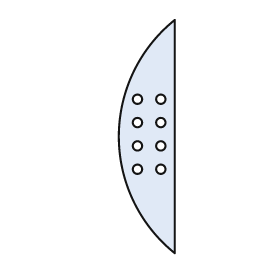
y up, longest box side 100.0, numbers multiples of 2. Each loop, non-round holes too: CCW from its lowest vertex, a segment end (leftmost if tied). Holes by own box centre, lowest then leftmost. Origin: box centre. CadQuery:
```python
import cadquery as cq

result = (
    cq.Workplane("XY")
    .moveTo(12.0, -50.0)
    .lineTo(12.0, 50.0)
    .threePointArc((-12.0, 0.0), (12.0, -50.0))
    .close()
    .moveTo(-4.0, -14.0)
    .circle(2.0)
    .moveTo(6.0, -14.0)
    .circle(2.0)
    .moveTo(-4.0, -4.0)
    .circle(2.0)
    .moveTo(6.0, -4.0)
    .circle(2.0)
    .moveTo(-4.0, 6.0)
    .circle(2.0)
    .moveTo(6.0, 6.0)
    .circle(2.0)
    .moveTo(-4.0, 16.0)
    .circle(2.0)
    .moveTo(6.0, 16.0)
    .circle(2.0)
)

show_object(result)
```